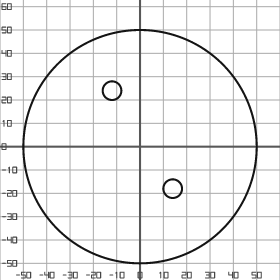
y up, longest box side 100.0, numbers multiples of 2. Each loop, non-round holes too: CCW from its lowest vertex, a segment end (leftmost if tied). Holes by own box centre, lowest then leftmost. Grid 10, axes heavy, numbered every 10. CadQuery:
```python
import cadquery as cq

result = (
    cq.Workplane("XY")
    .moveTo(0.0, 0.0)
    .circle(50.0)
    .moveTo(14.0, -18.0)
    .circle(4.0)
    .moveTo(-12.0, 24.0)
    .circle(4.0)
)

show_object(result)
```